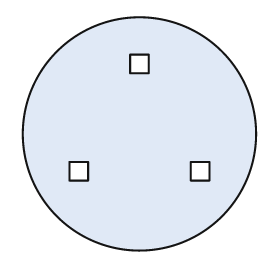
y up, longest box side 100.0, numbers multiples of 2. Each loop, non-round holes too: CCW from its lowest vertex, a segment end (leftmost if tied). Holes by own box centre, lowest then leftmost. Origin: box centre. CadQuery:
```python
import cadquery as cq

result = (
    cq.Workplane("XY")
    .moveTo(0.0, 0.0)
    .circle(50.0)
    .moveTo(-30.0, -20.0)
    .lineTo(-22.0, -20.0)
    .lineTo(-22.0, -12.0)
    .lineTo(-30.0, -12.0)
    .close()
    .moveTo(22.0, -20.0)
    .lineTo(30.0, -20.0)
    .lineTo(30.0, -12.0)
    .lineTo(22.0, -12.0)
    .close()
    .moveTo(-4.0, 26.0)
    .lineTo(4.0, 26.0)
    .lineTo(4.0, 34.0)
    .lineTo(-4.0, 34.0)
    .close()
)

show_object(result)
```